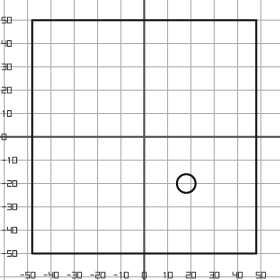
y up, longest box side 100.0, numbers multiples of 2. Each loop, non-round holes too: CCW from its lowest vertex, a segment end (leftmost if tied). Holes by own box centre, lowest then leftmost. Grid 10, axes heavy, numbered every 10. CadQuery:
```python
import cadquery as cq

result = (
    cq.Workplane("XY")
    .moveTo(-48.0, -50.0)
    .lineTo(48.0, -50.0)
    .lineTo(48.0, 50.0)
    .lineTo(-48.0, 50.0)
    .close()
    .moveTo(18.0, -20.0)
    .circle(4.0)
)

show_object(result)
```